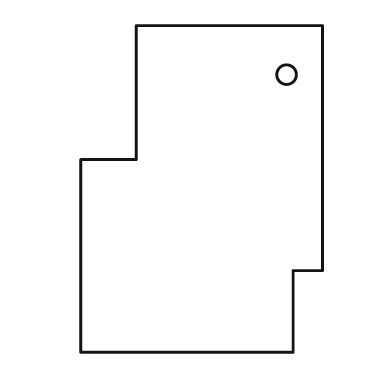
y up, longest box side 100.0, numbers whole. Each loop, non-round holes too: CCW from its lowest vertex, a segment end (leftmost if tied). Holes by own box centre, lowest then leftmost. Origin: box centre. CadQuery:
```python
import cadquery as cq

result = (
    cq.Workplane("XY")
    .moveTo(-37.0, -50.0)
    .lineTo(28.0, -50.0)
    .lineTo(28.0, -25.0)
    .lineTo(37.0, -25.0)
    .lineTo(37.0, 50.0)
    .lineTo(-20.0, 50.0)
    .lineTo(-20.0, 9.0)
    .lineTo(-37.0, 9.0)
    .close()
    .moveTo(26.0, 35.0)
    .circle(3.0)
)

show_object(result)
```